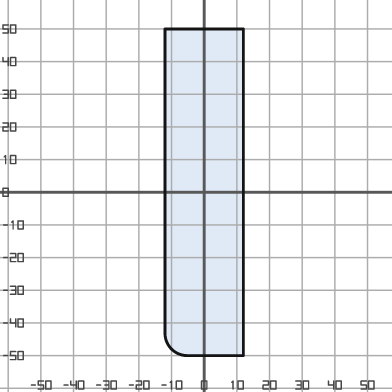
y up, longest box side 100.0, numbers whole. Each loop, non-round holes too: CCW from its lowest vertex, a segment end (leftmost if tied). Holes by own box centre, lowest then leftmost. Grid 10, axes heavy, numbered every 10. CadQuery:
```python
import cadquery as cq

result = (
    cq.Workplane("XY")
    .moveTo(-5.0, -50.0)
    .lineTo(12.0, -50.0)
    .lineTo(12.0, 50.0)
    .lineTo(-12.0, 50.0)
    .lineTo(-12.0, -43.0)
    .threePointArc((-10.0, -48.0), (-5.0, -50.0))
    .close()
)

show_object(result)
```